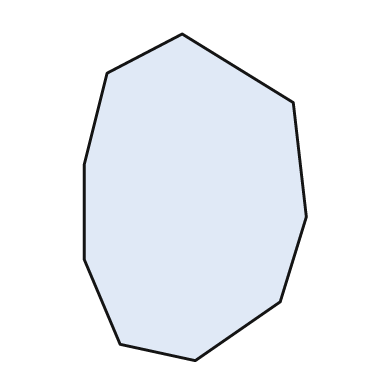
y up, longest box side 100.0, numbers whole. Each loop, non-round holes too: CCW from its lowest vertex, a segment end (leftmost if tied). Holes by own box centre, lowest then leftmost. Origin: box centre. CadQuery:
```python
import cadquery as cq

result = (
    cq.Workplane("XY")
    .moveTo(0.0, -50.0)
    .lineTo(26.0, -32.0)
    .lineTo(34.0, -6.0)
    .lineTo(30.0, 29.0)
    .lineTo(-4.0, 50.0)
    .lineTo(-27.0, 38.0)
    .lineTo(-34.0, 10.0)
    .lineTo(-34.0, -19.0)
    .lineTo(-23.0, -45.0)
    .close()
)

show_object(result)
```